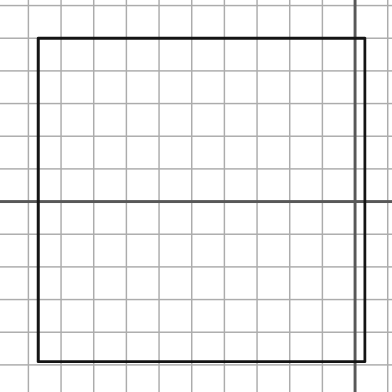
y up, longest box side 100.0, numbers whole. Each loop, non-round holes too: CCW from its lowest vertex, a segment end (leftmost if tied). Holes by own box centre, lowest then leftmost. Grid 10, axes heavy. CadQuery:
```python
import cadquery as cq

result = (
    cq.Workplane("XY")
    .moveTo(-97.0, -49.0)
    .lineTo(3.0, -49.0)
    .lineTo(3.0, 50.0)
    .lineTo(-97.0, 50.0)
    .close()
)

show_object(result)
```